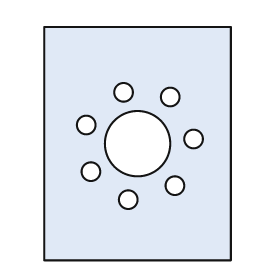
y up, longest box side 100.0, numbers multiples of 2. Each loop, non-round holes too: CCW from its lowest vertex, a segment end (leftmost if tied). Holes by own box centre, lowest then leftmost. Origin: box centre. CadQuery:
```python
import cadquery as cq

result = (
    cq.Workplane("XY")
    .moveTo(-40.0, -50.0)
    .lineTo(40.0, -50.0)
    .lineTo(40.0, 50.0)
    .lineTo(-40.0, 50.0)
    .close()
    .moveTo(-4.0, -24.0)
    .circle(4.0)
    .moveTo(16.0, -18.0)
    .circle(4.0)
    .moveTo(-20.0, -12.0)
    .circle(4.0)
    .moveTo(0.0, 0.0)
    .circle(14.0)
    .moveTo(24.0, 2.0)
    .circle(4.0)
    .moveTo(-22.0, 8.0)
    .circle(4.0)
    .moveTo(14.0, 20.0)
    .circle(4.0)
    .moveTo(-6.0, 22.0)
    .circle(4.0)
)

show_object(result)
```